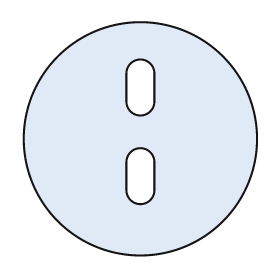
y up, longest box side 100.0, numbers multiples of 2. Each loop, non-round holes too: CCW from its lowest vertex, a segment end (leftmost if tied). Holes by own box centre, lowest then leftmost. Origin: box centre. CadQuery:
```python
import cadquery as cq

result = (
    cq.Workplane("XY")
    .moveTo(0.0, 0.0)
    .circle(50.0)
    .moveTo(-6.0, -22.0)
    .threePointArc((0.0, -28.0), (6.0, -22.0))
    .lineTo(6.0, -10.0)
    .threePointArc((0.0, -4.0), (-6.0, -10.0))
    .close()
    .moveTo(-6.0, 16.0)
    .threePointArc((0.0, 10.0), (6.0, 16.0))
    .lineTo(6.0, 28.0)
    .threePointArc((0.0, 34.0), (-6.0, 28.0))
    .close()
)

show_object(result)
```